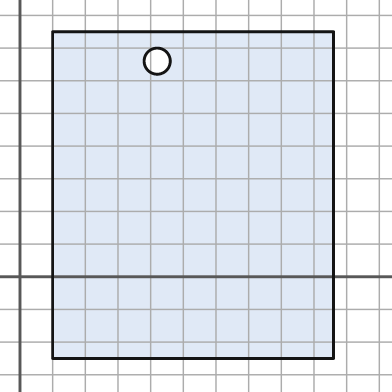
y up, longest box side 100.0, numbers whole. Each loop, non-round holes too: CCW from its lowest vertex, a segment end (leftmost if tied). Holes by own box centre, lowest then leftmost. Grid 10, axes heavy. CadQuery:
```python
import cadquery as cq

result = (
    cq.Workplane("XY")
    .moveTo(10.0, -25.0)
    .lineTo(96.0, -25.0)
    .lineTo(96.0, 75.0)
    .lineTo(10.0, 75.0)
    .close()
    .moveTo(42.0, 66.0)
    .circle(4.0)
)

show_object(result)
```